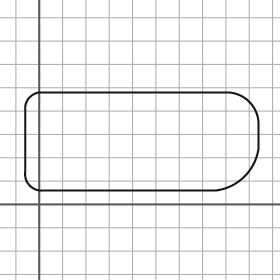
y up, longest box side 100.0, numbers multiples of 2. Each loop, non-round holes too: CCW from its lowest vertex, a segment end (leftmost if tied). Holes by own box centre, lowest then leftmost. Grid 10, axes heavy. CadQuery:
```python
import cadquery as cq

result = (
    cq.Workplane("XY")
    .moveTo(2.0, 6.0)
    .lineTo(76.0, 6.0)
    .threePointArc((88.0, 12.0), (94.0, 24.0))
    .lineTo(94.0, 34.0)
    .threePointArc((90.0, 44.0), (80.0, 48.0))
    .lineTo(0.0, 48.0)
    .threePointArc((-4.0, 46.0), (-6.0, 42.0))
    .lineTo(-6.0, 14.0)
    .threePointArc((-4.0, 8.0), (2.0, 6.0))
    .close()
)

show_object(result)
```